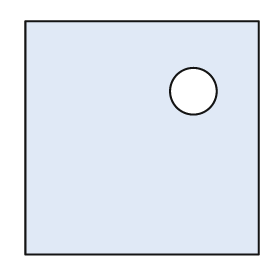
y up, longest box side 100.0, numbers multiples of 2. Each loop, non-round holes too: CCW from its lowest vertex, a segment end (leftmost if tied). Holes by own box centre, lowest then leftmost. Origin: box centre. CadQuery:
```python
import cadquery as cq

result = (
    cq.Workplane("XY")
    .moveTo(-50.0, -50.0)
    .lineTo(50.0, -50.0)
    .lineTo(50.0, 50.0)
    .lineTo(-50.0, 50.0)
    .close()
    .moveTo(22.0, 20.0)
    .circle(10.0)
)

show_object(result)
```